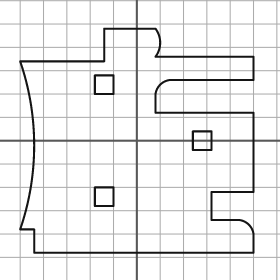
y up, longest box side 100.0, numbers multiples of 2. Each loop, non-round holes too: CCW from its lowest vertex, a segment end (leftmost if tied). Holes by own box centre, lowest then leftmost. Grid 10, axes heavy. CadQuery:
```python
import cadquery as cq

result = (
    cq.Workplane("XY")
    .moveTo(-44.0, -48.0)
    .lineTo(50.0, -48.0)
    .lineTo(50.0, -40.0)
    .threePointArc((48.0, -36.0), (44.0, -34.0))
    .lineTo(32.0, -34.0)
    .lineTo(32.0, -22.0)
    .lineTo(50.0, -22.0)
    .lineTo(50.0, 12.0)
    .lineTo(8.0, 12.0)
    .lineTo(8.0, 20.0)
    .threePointArc((10.0, 24.0), (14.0, 26.0))
    .lineTo(50.0, 26.0)
    .lineTo(50.0, 36.0)
    .lineTo(8.0, 36.0)
    .threePointArc((10.0, 42.0), (8.0, 48.0))
    .lineTo(-14.0, 48.0)
    .lineTo(-14.0, 34.0)
    .lineTo(-50.0, 34.0)
    .threePointArc((-44.0, -2.0), (-50.0, -38.0))
    .lineTo(-44.0, -38.0)
    .close()
    .moveTo(-18.0, -28.0)
    .lineTo(-10.0, -28.0)
    .lineTo(-10.0, -20.0)
    .lineTo(-18.0, -20.0)
    .close()
    .moveTo(24.0, -4.0)
    .lineTo(32.0, -4.0)
    .lineTo(32.0, 4.0)
    .lineTo(24.0, 4.0)
    .close()
    .moveTo(-18.0, 20.0)
    .lineTo(-10.0, 20.0)
    .lineTo(-10.0, 28.0)
    .lineTo(-18.0, 28.0)
    .close()
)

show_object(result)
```